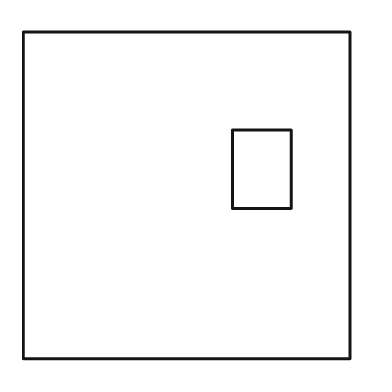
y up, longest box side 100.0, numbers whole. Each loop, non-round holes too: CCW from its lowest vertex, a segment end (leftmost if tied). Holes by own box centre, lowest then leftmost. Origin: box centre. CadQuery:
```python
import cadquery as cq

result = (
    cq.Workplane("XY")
    .moveTo(-50.0, -50.0)
    .lineTo(50.0, -50.0)
    .lineTo(50.0, 50.0)
    .lineTo(-50.0, 50.0)
    .close()
    .moveTo(14.0, -4.0)
    .lineTo(32.0, -4.0)
    .lineTo(32.0, 20.0)
    .lineTo(14.0, 20.0)
    .close()
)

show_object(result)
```